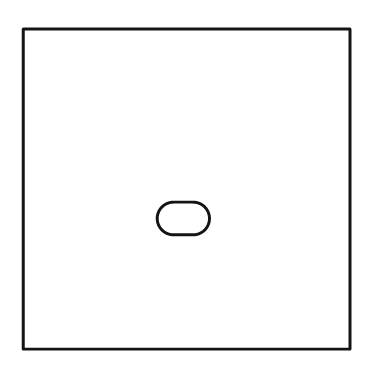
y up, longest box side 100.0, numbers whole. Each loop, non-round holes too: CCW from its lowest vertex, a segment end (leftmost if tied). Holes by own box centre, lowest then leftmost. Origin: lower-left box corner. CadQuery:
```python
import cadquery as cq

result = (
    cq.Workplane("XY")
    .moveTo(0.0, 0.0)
    .lineTo(100.0, 0.0)
    .lineTo(100.0, 98.0)
    .lineTo(0.0, 98.0)
    .close()
    .moveTo(46.0, 35.0)
    .lineTo(52.0, 35.0)
    .threePointArc((57.0, 40.0), (52.0, 45.0))
    .lineTo(46.0, 45.0)
    .threePointArc((41.0, 40.0), (46.0, 35.0))
    .close()
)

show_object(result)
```